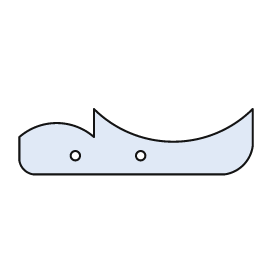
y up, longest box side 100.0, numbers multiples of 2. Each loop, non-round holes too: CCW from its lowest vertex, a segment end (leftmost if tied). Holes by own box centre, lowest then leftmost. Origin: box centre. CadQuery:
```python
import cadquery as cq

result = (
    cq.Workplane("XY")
    .moveTo(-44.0, -14.0)
    .lineTo(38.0, -14.0)
    .threePointArc((46.0, -10.0), (50.0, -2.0))
    .lineTo(50.0, 14.0)
    .threePointArc((16.0, 0.0), (-18.0, 14.0))
    .lineTo(-18.0, 2.0)
    .threePointArc((-34.0, 8.0), (-50.0, 2.0))
    .lineTo(-50.0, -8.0)
    .threePointArc((-48.0, -12.0), (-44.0, -14.0))
    .close()
    .moveTo(-26.0, -6.0)
    .circle(2.0)
    .moveTo(2.0, -6.0)
    .circle(2.0)
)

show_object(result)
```